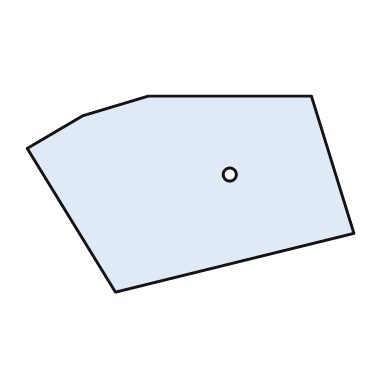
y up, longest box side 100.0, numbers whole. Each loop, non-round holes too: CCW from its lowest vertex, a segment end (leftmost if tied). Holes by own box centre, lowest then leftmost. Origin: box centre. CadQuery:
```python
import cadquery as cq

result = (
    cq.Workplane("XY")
    .moveTo(-23.0, -30.0)
    .lineTo(50.0, -12.0)
    .lineTo(37.0, 30.0)
    .lineTo(-13.0, 30.0)
    .lineTo(-33.0, 24.0)
    .lineTo(-50.0, 14.0)
    .close()
    .moveTo(12.0, 6.0)
    .circle(2.0)
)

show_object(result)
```